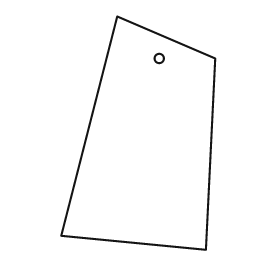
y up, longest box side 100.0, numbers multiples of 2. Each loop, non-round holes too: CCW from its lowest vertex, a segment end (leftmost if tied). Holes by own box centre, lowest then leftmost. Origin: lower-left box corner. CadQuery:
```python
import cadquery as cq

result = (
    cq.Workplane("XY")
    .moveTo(62.0, 0.0)
    .lineTo(66.0, 82.0)
    .lineTo(24.0, 100.0)
    .lineTo(0.0, 6.0)
    .close()
    .moveTo(42.0, 82.0)
    .circle(2.0)
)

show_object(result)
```